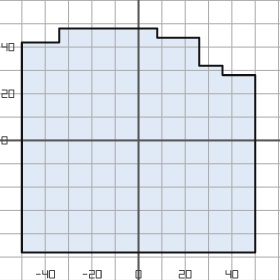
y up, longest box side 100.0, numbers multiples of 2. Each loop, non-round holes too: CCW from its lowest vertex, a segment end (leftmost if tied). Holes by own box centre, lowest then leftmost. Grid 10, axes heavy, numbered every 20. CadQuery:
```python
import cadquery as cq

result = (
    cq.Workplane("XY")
    .moveTo(-50.0, -48.0)
    .lineTo(50.0, -48.0)
    .lineTo(50.0, 28.0)
    .lineTo(36.0, 28.0)
    .lineTo(36.0, 32.0)
    .lineTo(26.0, 32.0)
    .lineTo(26.0, 44.0)
    .lineTo(8.0, 44.0)
    .lineTo(8.0, 48.0)
    .lineTo(-34.0, 48.0)
    .lineTo(-34.0, 42.0)
    .lineTo(-50.0, 42.0)
    .close()
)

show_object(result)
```